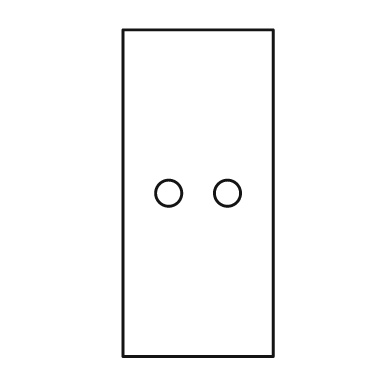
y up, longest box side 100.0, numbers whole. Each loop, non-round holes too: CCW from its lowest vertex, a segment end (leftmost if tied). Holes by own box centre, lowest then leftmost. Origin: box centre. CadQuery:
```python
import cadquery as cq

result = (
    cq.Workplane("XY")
    .moveTo(-23.0, -50.0)
    .lineTo(23.0, -50.0)
    .lineTo(23.0, 50.0)
    .lineTo(-23.0, 50.0)
    .close()
    .moveTo(-9.0, 0.0)
    .circle(4.0)
    .moveTo(9.0, 0.0)
    .circle(4.0)
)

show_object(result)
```